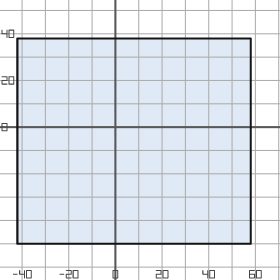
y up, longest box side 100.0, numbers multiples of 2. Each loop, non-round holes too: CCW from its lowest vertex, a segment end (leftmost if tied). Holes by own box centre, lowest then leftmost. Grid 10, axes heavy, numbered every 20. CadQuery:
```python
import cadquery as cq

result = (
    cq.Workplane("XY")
    .moveTo(-42.0, -50.0)
    .lineTo(58.0, -50.0)
    .lineTo(58.0, 38.0)
    .lineTo(-42.0, 38.0)
    .close()
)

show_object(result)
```